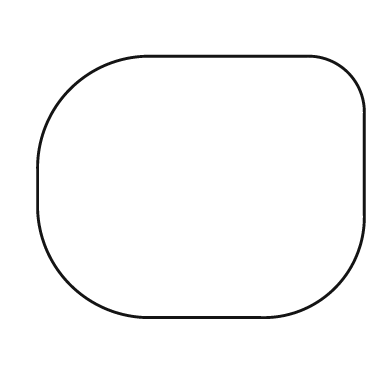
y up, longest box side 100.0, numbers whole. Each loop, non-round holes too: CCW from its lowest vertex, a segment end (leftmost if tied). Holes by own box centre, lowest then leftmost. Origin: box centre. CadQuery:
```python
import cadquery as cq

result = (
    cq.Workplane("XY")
    .moveTo(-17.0, -40.0)
    .lineTo(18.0, -40.0)
    .threePointArc((41.0, -31.0), (50.0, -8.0))
    .lineTo(50.0, 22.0)
    .threePointArc((45.0, 35.0), (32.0, 40.0))
    .lineTo(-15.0, 40.0)
    .threePointArc((-40.0, 30.0), (-50.0, 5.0))
    .lineTo(-50.0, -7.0)
    .threePointArc((-40.0, -30.0), (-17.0, -40.0))
    .close()
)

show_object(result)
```